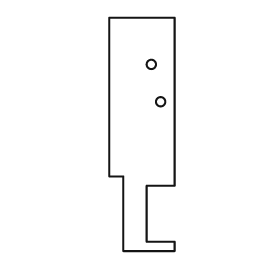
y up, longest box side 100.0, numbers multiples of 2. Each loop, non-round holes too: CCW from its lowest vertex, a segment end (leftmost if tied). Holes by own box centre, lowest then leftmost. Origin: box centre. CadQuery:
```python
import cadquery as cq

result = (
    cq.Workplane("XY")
    .moveTo(-8.0, -50.0)
    .lineTo(14.0, -50.0)
    .lineTo(14.0, -46.0)
    .lineTo(2.0, -46.0)
    .lineTo(2.0, -22.0)
    .lineTo(14.0, -22.0)
    .lineTo(14.0, 50.0)
    .lineTo(-14.0, 50.0)
    .lineTo(-14.0, -18.0)
    .lineTo(-8.0, -18.0)
    .close()
    .moveTo(8.0, 14.0)
    .circle(2.0)
    .moveTo(4.0, 30.0)
    .circle(2.0)
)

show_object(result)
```